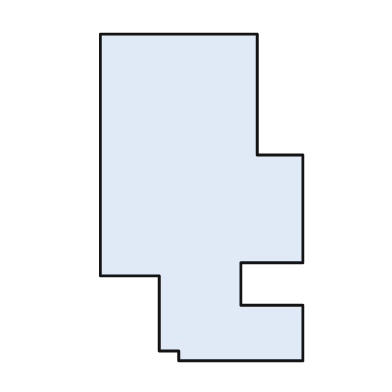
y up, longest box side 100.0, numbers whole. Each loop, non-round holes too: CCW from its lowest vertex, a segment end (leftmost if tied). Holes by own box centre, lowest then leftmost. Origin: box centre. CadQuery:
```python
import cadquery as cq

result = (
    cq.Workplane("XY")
    .moveTo(-7.0, -50.0)
    .lineTo(31.0, -50.0)
    .lineTo(31.0, -33.0)
    .lineTo(12.0, -33.0)
    .lineTo(12.0, -20.0)
    .lineTo(31.0, -20.0)
    .lineTo(31.0, 13.0)
    .lineTo(17.0, 13.0)
    .lineTo(17.0, 50.0)
    .lineTo(-31.0, 50.0)
    .lineTo(-31.0, -24.0)
    .lineTo(-13.0, -24.0)
    .lineTo(-13.0, -47.0)
    .lineTo(-7.0, -47.0)
    .close()
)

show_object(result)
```